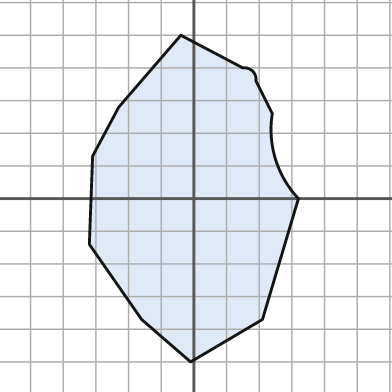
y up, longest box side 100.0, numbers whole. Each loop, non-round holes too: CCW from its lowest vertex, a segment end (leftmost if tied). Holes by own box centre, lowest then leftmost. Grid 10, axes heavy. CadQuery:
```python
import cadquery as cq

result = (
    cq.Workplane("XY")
    .moveTo(-1.0, -50.0)
    .lineTo(21.0, -37.0)
    .lineTo(32.0, 0.0)
    .threePointArc((25.0, 12.0), (24.0, 26.0))
    .lineTo(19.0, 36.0)
    .threePointArc((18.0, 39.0), (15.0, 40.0))
    .lineTo(-4.0, 50.0)
    .lineTo(-23.0, 28.0)
    .lineTo(-31.0, 13.0)
    .lineTo(-32.0, -14.0)
    .lineTo(-16.0, -37.0)
    .close()
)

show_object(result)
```